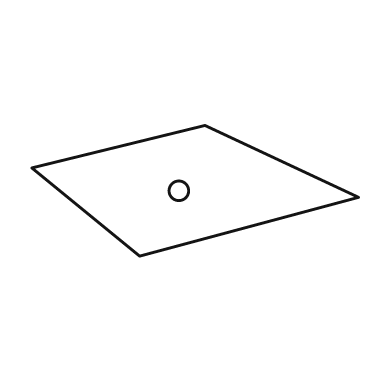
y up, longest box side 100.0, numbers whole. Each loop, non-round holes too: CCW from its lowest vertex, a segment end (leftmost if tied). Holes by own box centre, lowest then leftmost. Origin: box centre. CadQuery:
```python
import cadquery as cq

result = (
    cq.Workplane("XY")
    .moveTo(-17.0, -20.0)
    .lineTo(50.0, -2.0)
    .lineTo(3.0, 20.0)
    .lineTo(-50.0, 7.0)
    .close()
    .moveTo(-5.0, 0.0)
    .circle(3.0)
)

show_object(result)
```